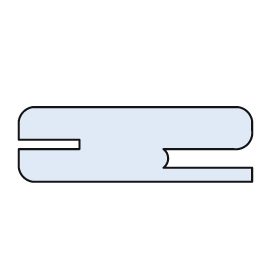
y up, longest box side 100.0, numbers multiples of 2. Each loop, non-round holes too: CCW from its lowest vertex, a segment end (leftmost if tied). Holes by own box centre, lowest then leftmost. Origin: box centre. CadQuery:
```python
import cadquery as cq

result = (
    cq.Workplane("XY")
    .moveTo(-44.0, -16.0)
    .lineTo(50.0, -16.0)
    .lineTo(50.0, -10.0)
    .lineTo(12.0, -10.0)
    .threePointArc((14.0, -6.0), (12.0, -2.0))
    .lineTo(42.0, -2.0)
    .threePointArc((48.0, 0.0), (50.0, 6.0))
    .lineTo(50.0, 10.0)
    .threePointArc((48.0, 14.0), (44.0, 16.0))
    .lineTo(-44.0, 16.0)
    .threePointArc((-48.0, 14.0), (-50.0, 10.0))
    .lineTo(-50.0, 2.0)
    .lineTo(-24.0, 2.0)
    .lineTo(-24.0, -2.0)
    .lineTo(-50.0, -2.0)
    .lineTo(-50.0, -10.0)
    .threePointArc((-48.0, -14.0), (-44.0, -16.0))
    .close()
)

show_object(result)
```